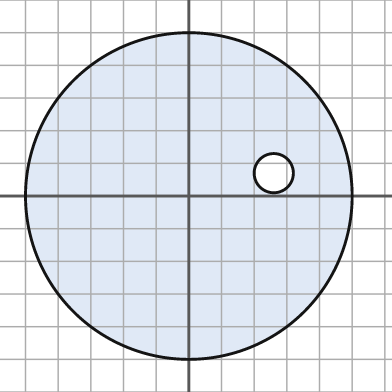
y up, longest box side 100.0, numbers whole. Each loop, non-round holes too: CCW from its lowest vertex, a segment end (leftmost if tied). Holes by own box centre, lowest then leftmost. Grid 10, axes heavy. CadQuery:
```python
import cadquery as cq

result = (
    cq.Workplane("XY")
    .moveTo(0.0, 0.0)
    .circle(50.0)
    .moveTo(26.0, 7.0)
    .circle(6.0)
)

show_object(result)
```